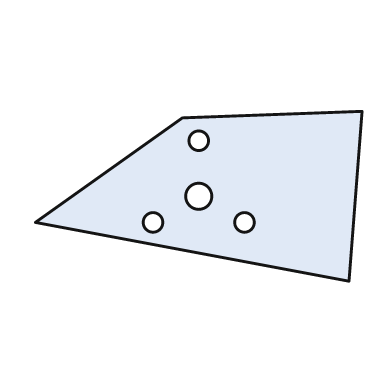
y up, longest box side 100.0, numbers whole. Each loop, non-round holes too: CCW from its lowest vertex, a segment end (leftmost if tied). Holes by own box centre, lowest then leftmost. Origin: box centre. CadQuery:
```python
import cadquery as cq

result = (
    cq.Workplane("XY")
    .moveTo(46.0, -26.0)
    .lineTo(50.0, 26.0)
    .lineTo(-5.0, 24.0)
    .lineTo(-50.0, -8.0)
    .close()
    .moveTo(-14.0, -8.0)
    .circle(3.0)
    .moveTo(14.0, -8.0)
    .circle(3.0)
    .moveTo(0.0, 0.0)
    .circle(4.0)
    .moveTo(0.0, 17.0)
    .circle(3.0)
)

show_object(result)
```